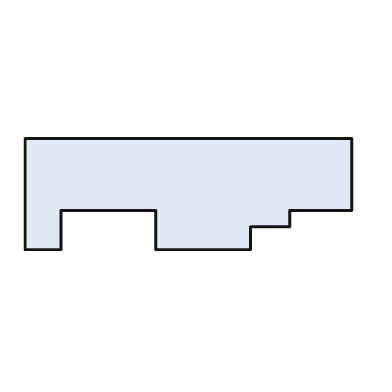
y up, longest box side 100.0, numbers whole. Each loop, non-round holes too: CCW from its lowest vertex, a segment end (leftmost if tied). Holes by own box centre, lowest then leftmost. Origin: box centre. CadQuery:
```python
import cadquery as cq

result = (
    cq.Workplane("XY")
    .moveTo(-50.0, -17.0)
    .lineTo(-39.0, -17.0)
    .lineTo(-39.0, -5.0)
    .lineTo(-10.0, -5.0)
    .lineTo(-10.0, -17.0)
    .lineTo(19.0, -17.0)
    .lineTo(19.0, -10.0)
    .lineTo(31.0, -10.0)
    .lineTo(31.0, -5.0)
    .lineTo(50.0, -5.0)
    .lineTo(50.0, 17.0)
    .lineTo(-50.0, 17.0)
    .close()
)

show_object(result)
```